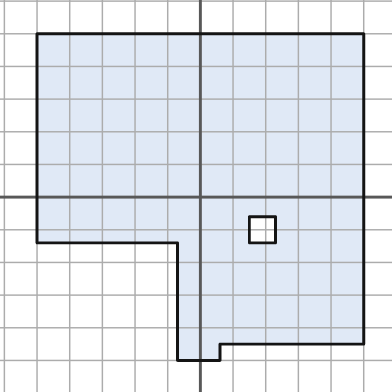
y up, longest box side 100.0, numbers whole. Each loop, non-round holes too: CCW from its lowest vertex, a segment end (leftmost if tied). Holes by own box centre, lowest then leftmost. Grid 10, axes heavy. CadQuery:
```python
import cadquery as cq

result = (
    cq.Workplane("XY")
    .moveTo(-7.0, -50.0)
    .lineTo(6.0, -50.0)
    .lineTo(6.0, -45.0)
    .lineTo(50.0, -45.0)
    .lineTo(50.0, 50.0)
    .lineTo(-50.0, 50.0)
    .lineTo(-50.0, -14.0)
    .lineTo(-7.0, -14.0)
    .close()
    .moveTo(15.0, -14.0)
    .lineTo(23.0, -14.0)
    .lineTo(23.0, -6.0)
    .lineTo(15.0, -6.0)
    .close()
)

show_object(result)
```